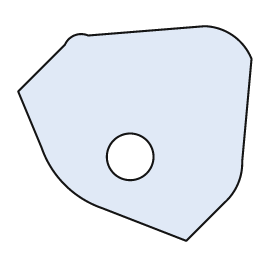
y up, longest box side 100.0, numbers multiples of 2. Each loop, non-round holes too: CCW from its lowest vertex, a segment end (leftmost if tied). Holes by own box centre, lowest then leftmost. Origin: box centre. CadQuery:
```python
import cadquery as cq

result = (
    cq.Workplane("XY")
    .moveTo(22.0, -46.0)
    .lineTo(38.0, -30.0)
    .threePointArc((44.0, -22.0), (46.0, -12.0))
    .lineTo(50.0, 32.0)
    .threePointArc((42.0, 42.0), (30.0, 46.0))
    .lineTo(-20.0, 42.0)
    .threePointArc((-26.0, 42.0), (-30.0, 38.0))
    .lineTo(-50.0, 18.0)
    .lineTo(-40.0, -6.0)
    .threePointArc((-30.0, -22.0), (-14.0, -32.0))
    .close()
    .moveTo(-2.0, -10.0)
    .circle(10.0)
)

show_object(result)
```